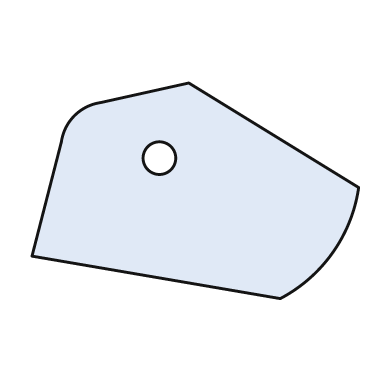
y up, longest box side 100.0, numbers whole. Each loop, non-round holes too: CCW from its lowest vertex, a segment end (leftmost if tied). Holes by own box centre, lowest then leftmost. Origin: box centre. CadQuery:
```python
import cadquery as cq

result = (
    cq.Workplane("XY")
    .moveTo(26.0, -33.0)
    .threePointArc((42.0, -19.0), (50.0, 1.0))
    .lineTo(-2.0, 33.0)
    .lineTo(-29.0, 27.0)
    .threePointArc((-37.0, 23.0), (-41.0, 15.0))
    .lineTo(-50.0, -20.0)
    .close()
    .moveTo(-11.0, 10.0)
    .circle(5.0)
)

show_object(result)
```